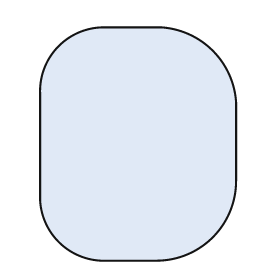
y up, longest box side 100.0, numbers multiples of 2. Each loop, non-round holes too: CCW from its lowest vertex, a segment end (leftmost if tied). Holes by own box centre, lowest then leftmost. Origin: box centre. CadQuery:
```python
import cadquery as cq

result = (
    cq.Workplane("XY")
    .moveTo(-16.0, -50.0)
    .lineTo(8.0, -50.0)
    .threePointArc((32.0, -40.0), (42.0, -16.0))
    .lineTo(42.0, 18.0)
    .threePointArc((32.0, 40.0), (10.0, 50.0))
    .lineTo(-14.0, 50.0)
    .threePointArc((-34.0, 42.0), (-42.0, 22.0))
    .lineTo(-42.0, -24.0)
    .threePointArc((-34.0, -42.0), (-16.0, -50.0))
    .close()
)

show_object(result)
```